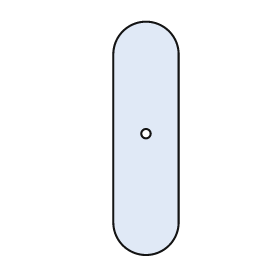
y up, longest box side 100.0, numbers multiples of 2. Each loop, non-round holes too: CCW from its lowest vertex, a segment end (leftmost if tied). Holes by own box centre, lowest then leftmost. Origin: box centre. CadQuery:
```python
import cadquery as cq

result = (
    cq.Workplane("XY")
    .moveTo(-14.0, -36.0)
    .threePointArc((0.0, -50.0), (14.0, -36.0))
    .lineTo(14.0, 36.0)
    .threePointArc((0.0, 50.0), (-14.0, 36.0))
    .close()
    .moveTo(0.0, 2.0)
    .circle(2.0)
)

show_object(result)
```